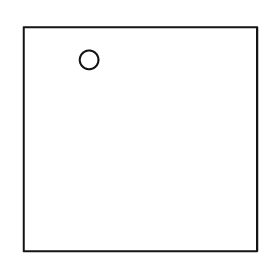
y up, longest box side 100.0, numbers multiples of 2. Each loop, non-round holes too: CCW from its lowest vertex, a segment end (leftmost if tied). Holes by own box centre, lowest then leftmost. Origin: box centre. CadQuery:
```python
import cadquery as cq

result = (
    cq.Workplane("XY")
    .moveTo(-50.0, -48.0)
    .lineTo(50.0, -48.0)
    .lineTo(50.0, 48.0)
    .lineTo(-50.0, 48.0)
    .close()
    .moveTo(-22.0, 34.0)
    .circle(4.0)
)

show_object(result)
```